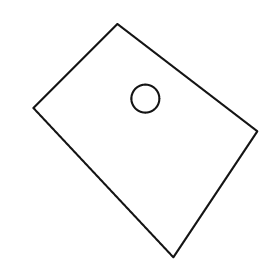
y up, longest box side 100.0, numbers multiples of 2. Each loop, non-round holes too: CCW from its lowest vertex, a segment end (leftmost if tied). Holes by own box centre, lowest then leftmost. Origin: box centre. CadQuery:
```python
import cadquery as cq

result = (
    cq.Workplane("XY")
    .moveTo(12.0, -50.0)
    .lineTo(48.0, 4.0)
    .lineTo(-12.0, 50.0)
    .lineTo(-48.0, 14.0)
    .close()
    .moveTo(0.0, 18.0)
    .circle(6.0)
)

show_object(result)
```